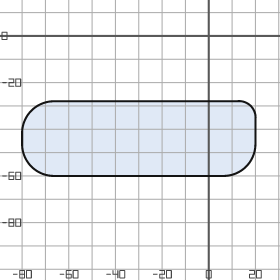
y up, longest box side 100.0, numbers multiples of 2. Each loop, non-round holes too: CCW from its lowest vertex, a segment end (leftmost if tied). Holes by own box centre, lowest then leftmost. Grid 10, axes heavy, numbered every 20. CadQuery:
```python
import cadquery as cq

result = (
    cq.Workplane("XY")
    .moveTo(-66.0, -60.0)
    .lineTo(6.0, -60.0)
    .threePointArc((16.0, -56.0), (20.0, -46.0))
    .lineTo(20.0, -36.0)
    .threePointArc((18.0, -30.0), (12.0, -28.0))
    .lineTo(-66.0, -28.0)
    .threePointArc((-76.0, -32.0), (-80.0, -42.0))
    .lineTo(-80.0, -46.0)
    .threePointArc((-76.0, -56.0), (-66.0, -60.0))
    .close()
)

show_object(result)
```